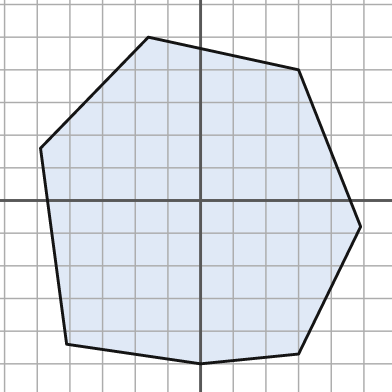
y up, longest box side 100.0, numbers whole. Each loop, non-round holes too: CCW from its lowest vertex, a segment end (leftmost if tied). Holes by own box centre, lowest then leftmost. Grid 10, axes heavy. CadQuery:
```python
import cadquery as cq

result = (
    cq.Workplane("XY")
    .moveTo(0.0, -50.0)
    .lineTo(30.0, -47.0)
    .lineTo(49.0, -8.0)
    .lineTo(30.0, 40.0)
    .lineTo(-16.0, 50.0)
    .lineTo(-49.0, 16.0)
    .lineTo(-41.0, -44.0)
    .close()
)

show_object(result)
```